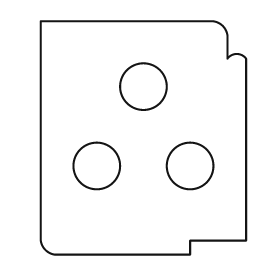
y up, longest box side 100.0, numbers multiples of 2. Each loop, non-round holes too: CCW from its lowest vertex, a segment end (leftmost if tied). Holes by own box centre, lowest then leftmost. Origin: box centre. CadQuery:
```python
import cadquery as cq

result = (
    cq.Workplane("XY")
    .moveTo(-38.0, -50.0)
    .lineTo(20.0, -50.0)
    .lineTo(20.0, -44.0)
    .lineTo(44.0, -44.0)
    .lineTo(44.0, 34.0)
    .threePointArc((40.0, 36.0), (36.0, 34.0))
    .lineTo(36.0, 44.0)
    .threePointArc((34.0, 48.0), (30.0, 50.0))
    .lineTo(-44.0, 50.0)
    .lineTo(-44.0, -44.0)
    .threePointArc((-42.0, -48.0), (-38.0, -50.0))
    .close()
    .moveTo(-20.0, -12.0)
    .circle(10.0)
    .moveTo(20.0, -12.0)
    .circle(10.0)
    .moveTo(0.0, 22.0)
    .circle(10.0)
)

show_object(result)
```